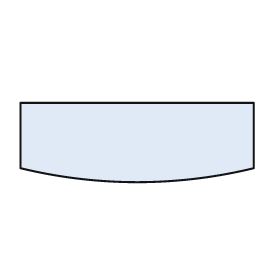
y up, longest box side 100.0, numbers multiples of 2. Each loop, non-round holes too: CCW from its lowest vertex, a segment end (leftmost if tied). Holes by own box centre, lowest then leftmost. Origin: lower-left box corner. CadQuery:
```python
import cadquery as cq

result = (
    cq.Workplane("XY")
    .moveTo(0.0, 6.0)
    .threePointArc((50.0, 0.0), (100.0, 6.0))
    .lineTo(100.0, 34.0)
    .lineTo(0.0, 34.0)
    .close()
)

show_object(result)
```